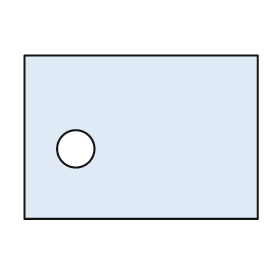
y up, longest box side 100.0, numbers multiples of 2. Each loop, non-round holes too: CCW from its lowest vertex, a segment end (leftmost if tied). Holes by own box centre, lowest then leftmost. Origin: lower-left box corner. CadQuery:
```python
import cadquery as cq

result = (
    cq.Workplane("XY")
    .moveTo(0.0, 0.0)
    .lineTo(100.0, 0.0)
    .lineTo(100.0, 70.0)
    .lineTo(0.0, 70.0)
    .close()
    .moveTo(22.0, 30.0)
    .circle(8.0)
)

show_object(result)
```